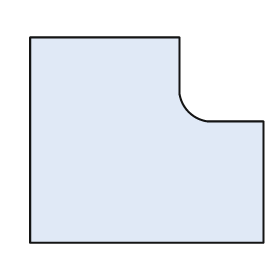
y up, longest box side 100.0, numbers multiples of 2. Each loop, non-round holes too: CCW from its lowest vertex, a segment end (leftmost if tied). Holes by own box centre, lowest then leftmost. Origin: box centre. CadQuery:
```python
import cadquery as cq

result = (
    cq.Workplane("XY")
    .moveTo(-50.0, -44.0)
    .lineTo(50.0, -44.0)
    .lineTo(50.0, 8.0)
    .lineTo(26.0, 8.0)
    .threePointArc((18.0, 12.0), (14.0, 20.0))
    .lineTo(14.0, 44.0)
    .lineTo(-50.0, 44.0)
    .close()
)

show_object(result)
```